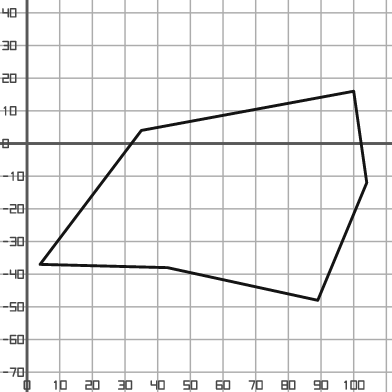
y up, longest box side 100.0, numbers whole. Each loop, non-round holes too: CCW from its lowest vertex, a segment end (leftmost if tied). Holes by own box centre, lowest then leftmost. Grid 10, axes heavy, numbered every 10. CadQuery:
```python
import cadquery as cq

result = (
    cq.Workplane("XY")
    .moveTo(89.0, -48.0)
    .lineTo(104.0, -12.0)
    .lineTo(100.0, 16.0)
    .lineTo(35.0, 4.0)
    .lineTo(4.0, -37.0)
    .lineTo(43.0, -38.0)
    .close()
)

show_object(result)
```